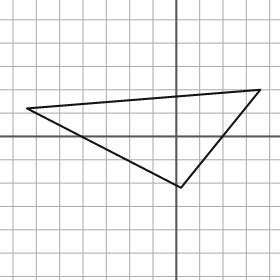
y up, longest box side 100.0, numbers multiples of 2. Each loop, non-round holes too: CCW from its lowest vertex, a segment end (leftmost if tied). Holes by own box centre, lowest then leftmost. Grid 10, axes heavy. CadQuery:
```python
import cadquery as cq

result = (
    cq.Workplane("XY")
    .moveTo(2.0, -22.0)
    .lineTo(36.0, 20.0)
    .lineTo(-64.0, 12.0)
    .close()
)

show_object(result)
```